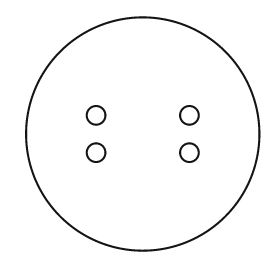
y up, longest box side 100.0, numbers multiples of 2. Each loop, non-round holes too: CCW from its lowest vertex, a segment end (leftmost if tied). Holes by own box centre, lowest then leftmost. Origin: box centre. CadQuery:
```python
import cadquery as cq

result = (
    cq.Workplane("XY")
    .moveTo(0.0, 0.0)
    .circle(50.0)
    .moveTo(-20.0, -8.0)
    .circle(4.0)
    .moveTo(20.0, -8.0)
    .circle(4.0)
    .moveTo(-20.0, 8.0)
    .circle(4.0)
    .moveTo(20.0, 8.0)
    .circle(4.0)
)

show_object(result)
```